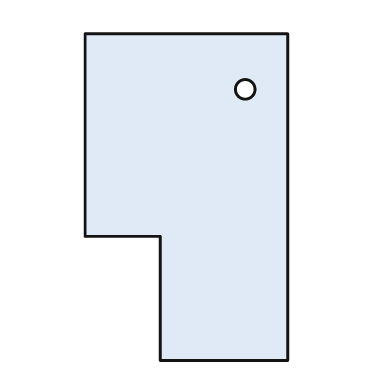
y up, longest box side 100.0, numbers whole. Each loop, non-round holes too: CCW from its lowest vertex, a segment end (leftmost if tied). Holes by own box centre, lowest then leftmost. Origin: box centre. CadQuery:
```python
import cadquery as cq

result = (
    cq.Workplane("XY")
    .moveTo(-8.0, -50.0)
    .lineTo(31.0, -50.0)
    .lineTo(31.0, 50.0)
    .lineTo(-31.0, 50.0)
    .lineTo(-31.0, -12.0)
    .lineTo(-8.0, -12.0)
    .close()
    .moveTo(18.0, 33.0)
    .circle(3.0)
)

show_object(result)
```